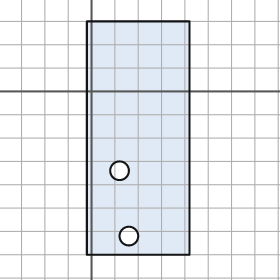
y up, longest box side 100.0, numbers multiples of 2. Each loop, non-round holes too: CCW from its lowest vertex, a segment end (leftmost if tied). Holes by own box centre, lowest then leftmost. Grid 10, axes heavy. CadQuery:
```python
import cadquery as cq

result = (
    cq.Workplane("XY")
    .moveTo(-2.0, -70.0)
    .lineTo(42.0, -70.0)
    .lineTo(42.0, 30.0)
    .lineTo(-2.0, 30.0)
    .close()
    .moveTo(16.0, -62.0)
    .circle(4.0)
    .moveTo(12.0, -34.0)
    .circle(4.0)
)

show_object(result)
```